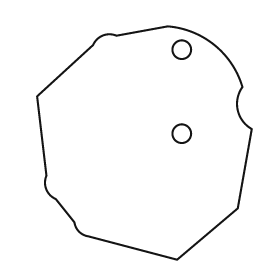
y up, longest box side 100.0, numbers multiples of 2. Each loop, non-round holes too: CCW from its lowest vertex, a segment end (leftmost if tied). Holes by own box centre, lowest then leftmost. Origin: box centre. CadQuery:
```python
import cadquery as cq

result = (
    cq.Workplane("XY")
    .moveTo(14.0, -50.0)
    .lineTo(40.0, -28.0)
    .lineTo(46.0, 6.0)
    .threePointArc((40.0, 14.0), (42.0, 24.0))
    .threePointArc((30.0, 42.0), (10.0, 50.0))
    .lineTo(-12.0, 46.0)
    .threePointArc((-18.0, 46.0), (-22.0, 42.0))
    .lineTo(-46.0, 20.0)
    .lineTo(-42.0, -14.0)
    .threePointArc((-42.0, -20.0), (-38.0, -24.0))
    .lineTo(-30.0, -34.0)
    .threePointArc((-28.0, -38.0), (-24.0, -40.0))
    .close()
    .moveTo(16.0, 4.0)
    .circle(4.0)
    .moveTo(16.0, 40.0)
    .circle(4.0)
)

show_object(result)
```